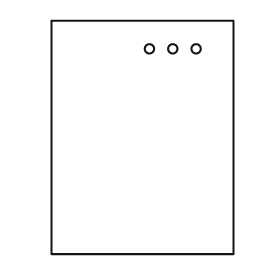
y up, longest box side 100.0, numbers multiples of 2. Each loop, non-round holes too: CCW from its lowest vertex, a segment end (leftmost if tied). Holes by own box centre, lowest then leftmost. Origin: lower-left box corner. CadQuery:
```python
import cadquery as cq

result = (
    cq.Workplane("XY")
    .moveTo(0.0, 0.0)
    .lineTo(78.0, 0.0)
    .lineTo(78.0, 100.0)
    .lineTo(0.0, 100.0)
    .close()
    .moveTo(42.0, 88.0)
    .circle(2.0)
    .moveTo(52.0, 88.0)
    .circle(2.0)
    .moveTo(62.0, 88.0)
    .circle(2.0)
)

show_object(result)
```